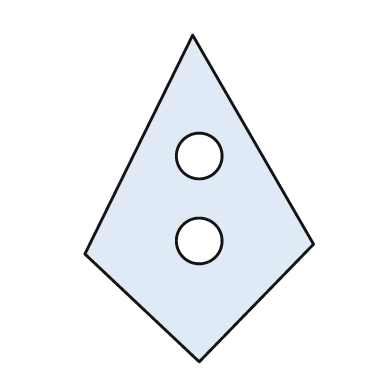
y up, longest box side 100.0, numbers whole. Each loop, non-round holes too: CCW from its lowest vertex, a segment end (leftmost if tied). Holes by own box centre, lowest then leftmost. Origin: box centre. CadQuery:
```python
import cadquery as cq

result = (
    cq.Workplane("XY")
    .moveTo(0.0, -50.0)
    .lineTo(35.0, -14.0)
    .lineTo(-2.0, 50.0)
    .lineTo(-35.0, -17.0)
    .close()
    .moveTo(0.0, -13.0)
    .circle(7.0)
    .moveTo(0.0, 13.0)
    .circle(7.0)
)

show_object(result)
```